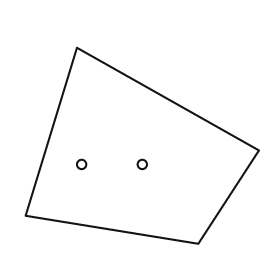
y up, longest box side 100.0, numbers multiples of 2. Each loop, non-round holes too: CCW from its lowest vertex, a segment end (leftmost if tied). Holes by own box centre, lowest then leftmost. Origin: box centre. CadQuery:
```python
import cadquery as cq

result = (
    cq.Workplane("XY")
    .moveTo(24.0, -42.0)
    .lineTo(50.0, -2.0)
    .lineTo(-28.0, 42.0)
    .lineTo(-50.0, -30.0)
    .close()
    .moveTo(-26.0, -8.0)
    .circle(2.0)
    .moveTo(0.0, -8.0)
    .circle(2.0)
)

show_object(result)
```